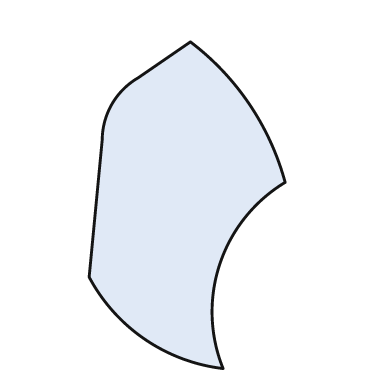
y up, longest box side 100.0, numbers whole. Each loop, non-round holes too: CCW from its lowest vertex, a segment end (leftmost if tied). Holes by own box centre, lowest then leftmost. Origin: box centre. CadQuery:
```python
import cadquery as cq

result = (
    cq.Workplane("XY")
    .moveTo(11.0, -50.0)
    .threePointArc((10.0, -18.0), (30.0, 7.0))
    .threePointArc((19.0, 31.0), (1.0, 50.0))
    .lineTo(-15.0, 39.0)
    .threePointArc((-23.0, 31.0), (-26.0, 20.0))
    .lineTo(-30.0, -22.0)
    .threePointArc((-13.0, -41.0), (11.0, -50.0))
    .close()
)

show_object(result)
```